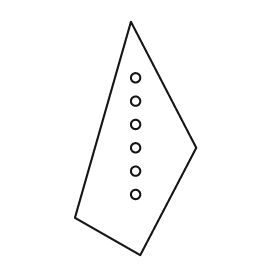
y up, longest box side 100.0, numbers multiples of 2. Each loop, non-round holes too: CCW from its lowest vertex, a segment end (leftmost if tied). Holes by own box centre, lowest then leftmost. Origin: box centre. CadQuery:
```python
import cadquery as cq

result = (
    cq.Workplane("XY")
    .moveTo(2.0, -50.0)
    .lineTo(26.0, -4.0)
    .lineTo(-2.0, 50.0)
    .lineTo(-26.0, -34.0)
    .close()
    .moveTo(0.0, -24.0)
    .circle(2.0)
    .moveTo(0.0, -14.0)
    .circle(2.0)
    .moveTo(0.0, -4.0)
    .circle(2.0)
    .moveTo(0.0, 6.0)
    .circle(2.0)
    .moveTo(0.0, 16.0)
    .circle(2.0)
    .moveTo(0.0, 26.0)
    .circle(2.0)
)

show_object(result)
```